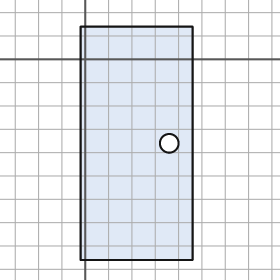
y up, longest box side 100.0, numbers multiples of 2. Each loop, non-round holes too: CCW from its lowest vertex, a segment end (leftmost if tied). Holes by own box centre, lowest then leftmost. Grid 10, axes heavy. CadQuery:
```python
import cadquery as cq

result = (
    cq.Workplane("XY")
    .moveTo(-2.0, -86.0)
    .lineTo(46.0, -86.0)
    .lineTo(46.0, 14.0)
    .lineTo(-2.0, 14.0)
    .close()
    .moveTo(36.0, -36.0)
    .circle(4.0)
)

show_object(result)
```